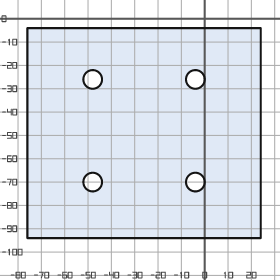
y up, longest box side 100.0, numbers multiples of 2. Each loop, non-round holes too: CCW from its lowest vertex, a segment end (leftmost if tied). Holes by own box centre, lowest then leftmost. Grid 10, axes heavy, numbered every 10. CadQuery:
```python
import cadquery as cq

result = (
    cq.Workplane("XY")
    .moveTo(-76.0, -94.0)
    .lineTo(24.0, -94.0)
    .lineTo(24.0, -4.0)
    .lineTo(-76.0, -4.0)
    .close()
    .moveTo(-48.0, -70.0)
    .circle(4.0)
    .moveTo(-4.0, -70.0)
    .circle(4.0)
    .moveTo(-48.0, -26.0)
    .circle(4.0)
    .moveTo(-4.0, -26.0)
    .circle(4.0)
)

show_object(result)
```